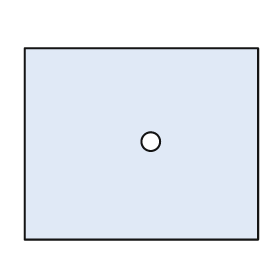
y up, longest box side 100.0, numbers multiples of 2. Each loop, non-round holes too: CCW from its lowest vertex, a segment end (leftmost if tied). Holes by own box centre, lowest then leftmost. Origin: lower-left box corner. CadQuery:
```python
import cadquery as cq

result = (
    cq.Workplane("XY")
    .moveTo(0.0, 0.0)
    .lineTo(100.0, 0.0)
    .lineTo(100.0, 82.0)
    .lineTo(0.0, 82.0)
    .close()
    .moveTo(54.0, 42.0)
    .circle(4.0)
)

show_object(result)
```